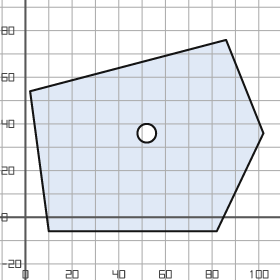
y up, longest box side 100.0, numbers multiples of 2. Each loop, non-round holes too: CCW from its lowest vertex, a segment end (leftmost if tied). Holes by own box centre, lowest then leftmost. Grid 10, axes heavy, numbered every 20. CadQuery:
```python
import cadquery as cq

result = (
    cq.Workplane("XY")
    .moveTo(10.0, -6.0)
    .lineTo(82.0, -6.0)
    .lineTo(102.0, 36.0)
    .lineTo(86.0, 76.0)
    .lineTo(2.0, 54.0)
    .close()
    .moveTo(52.0, 36.0)
    .circle(4.0)
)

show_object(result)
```